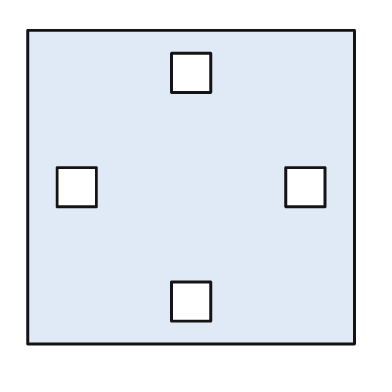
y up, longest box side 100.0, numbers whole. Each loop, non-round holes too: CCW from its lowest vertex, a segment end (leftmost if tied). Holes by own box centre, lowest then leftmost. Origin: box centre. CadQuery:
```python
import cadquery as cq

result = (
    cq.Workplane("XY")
    .moveTo(-50.0, -48.0)
    .lineTo(50.0, -48.0)
    .lineTo(50.0, 48.0)
    .lineTo(-50.0, 48.0)
    .close()
    .moveTo(-6.0, -41.0)
    .lineTo(6.0, -41.0)
    .lineTo(6.0, -29.0)
    .lineTo(-6.0, -29.0)
    .close()
    .moveTo(-41.0, -6.0)
    .lineTo(-29.0, -6.0)
    .lineTo(-29.0, 6.0)
    .lineTo(-41.0, 6.0)
    .close()
    .moveTo(29.0, -6.0)
    .lineTo(41.0, -6.0)
    .lineTo(41.0, 6.0)
    .lineTo(29.0, 6.0)
    .close()
    .moveTo(-6.0, 29.0)
    .lineTo(6.0, 29.0)
    .lineTo(6.0, 41.0)
    .lineTo(-6.0, 41.0)
    .close()
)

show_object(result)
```